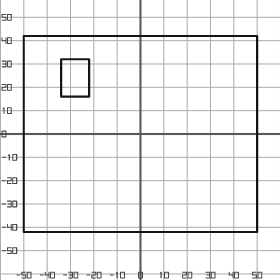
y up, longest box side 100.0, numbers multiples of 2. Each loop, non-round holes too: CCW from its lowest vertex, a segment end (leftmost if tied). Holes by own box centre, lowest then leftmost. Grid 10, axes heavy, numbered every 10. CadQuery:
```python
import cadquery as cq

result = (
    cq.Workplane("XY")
    .moveTo(-50.0, -42.0)
    .lineTo(50.0, -42.0)
    .lineTo(50.0, 42.0)
    .lineTo(-50.0, 42.0)
    .close()
    .moveTo(-34.0, 16.0)
    .lineTo(-22.0, 16.0)
    .lineTo(-22.0, 32.0)
    .lineTo(-34.0, 32.0)
    .close()
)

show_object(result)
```